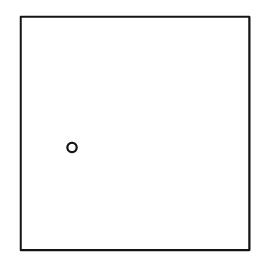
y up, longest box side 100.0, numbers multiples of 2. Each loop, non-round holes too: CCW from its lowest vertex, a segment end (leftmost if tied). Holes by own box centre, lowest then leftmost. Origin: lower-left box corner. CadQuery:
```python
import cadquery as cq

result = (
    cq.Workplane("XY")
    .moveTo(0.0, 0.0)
    .lineTo(98.0, 0.0)
    .lineTo(98.0, 100.0)
    .lineTo(0.0, 100.0)
    .close()
    .moveTo(22.0, 44.0)
    .circle(2.0)
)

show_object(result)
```